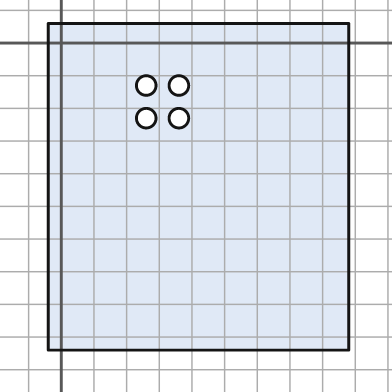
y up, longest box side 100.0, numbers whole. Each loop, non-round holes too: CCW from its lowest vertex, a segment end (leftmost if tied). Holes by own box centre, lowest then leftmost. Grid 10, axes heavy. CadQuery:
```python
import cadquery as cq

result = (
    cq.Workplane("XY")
    .moveTo(-4.0, -94.0)
    .lineTo(88.0, -94.0)
    .lineTo(88.0, 6.0)
    .lineTo(-4.0, 6.0)
    .close()
    .moveTo(26.0, -23.0)
    .circle(3.0)
    .moveTo(36.0, -23.0)
    .circle(3.0)
    .moveTo(26.0, -13.0)
    .circle(3.0)
    .moveTo(36.0, -13.0)
    .circle(3.0)
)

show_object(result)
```